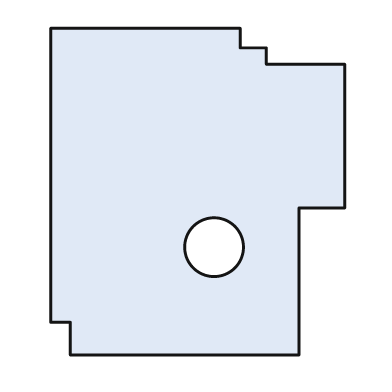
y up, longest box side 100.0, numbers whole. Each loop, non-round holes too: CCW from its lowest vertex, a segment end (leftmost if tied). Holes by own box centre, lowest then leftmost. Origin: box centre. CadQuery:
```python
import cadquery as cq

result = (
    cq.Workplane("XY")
    .moveTo(-39.0, -50.0)
    .lineTo(31.0, -50.0)
    .lineTo(31.0, -5.0)
    .lineTo(45.0, -5.0)
    .lineTo(45.0, 39.0)
    .lineTo(21.0, 39.0)
    .lineTo(21.0, 44.0)
    .lineTo(13.0, 44.0)
    .lineTo(13.0, 50.0)
    .lineTo(-45.0, 50.0)
    .lineTo(-45.0, -40.0)
    .lineTo(-39.0, -40.0)
    .close()
    .moveTo(5.0, -17.0)
    .circle(9.0)
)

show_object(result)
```